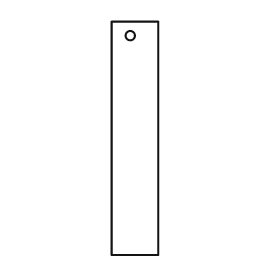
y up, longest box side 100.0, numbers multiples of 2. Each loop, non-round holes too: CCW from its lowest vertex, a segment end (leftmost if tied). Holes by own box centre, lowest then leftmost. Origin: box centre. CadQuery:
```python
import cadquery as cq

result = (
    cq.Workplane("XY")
    .moveTo(-10.0, -50.0)
    .lineTo(10.0, -50.0)
    .lineTo(10.0, 50.0)
    .lineTo(-10.0, 50.0)
    .close()
    .moveTo(-2.0, 44.0)
    .circle(2.0)
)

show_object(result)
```